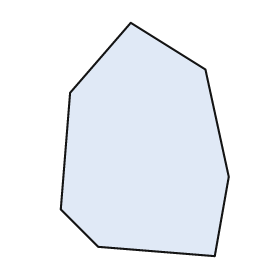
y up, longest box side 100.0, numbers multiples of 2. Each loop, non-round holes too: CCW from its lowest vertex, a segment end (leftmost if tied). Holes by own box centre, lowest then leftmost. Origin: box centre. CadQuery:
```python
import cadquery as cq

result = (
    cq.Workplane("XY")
    .moveTo(30.0, -50.0)
    .lineTo(36.0, -16.0)
    .lineTo(26.0, 30.0)
    .lineTo(-6.0, 50.0)
    .lineTo(-32.0, 20.0)
    .lineTo(-36.0, -30.0)
    .lineTo(-20.0, -46.0)
    .close()
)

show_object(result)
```